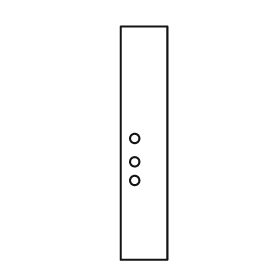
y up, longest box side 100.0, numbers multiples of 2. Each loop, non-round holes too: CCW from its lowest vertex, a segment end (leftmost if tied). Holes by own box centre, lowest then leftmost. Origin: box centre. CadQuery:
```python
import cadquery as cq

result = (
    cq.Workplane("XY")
    .moveTo(-10.0, -50.0)
    .lineTo(10.0, -50.0)
    .lineTo(10.0, 50.0)
    .lineTo(-10.0, 50.0)
    .close()
    .moveTo(-4.0, -16.0)
    .circle(2.0)
    .moveTo(-4.0, -8.0)
    .circle(2.0)
    .moveTo(-4.0, 2.0)
    .circle(2.0)
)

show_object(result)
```